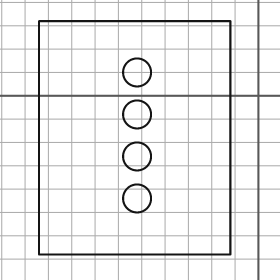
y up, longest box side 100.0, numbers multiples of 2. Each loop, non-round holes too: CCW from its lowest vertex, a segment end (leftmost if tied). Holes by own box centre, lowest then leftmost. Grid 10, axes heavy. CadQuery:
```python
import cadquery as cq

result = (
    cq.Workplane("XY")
    .moveTo(-94.0, -68.0)
    .lineTo(-12.0, -68.0)
    .lineTo(-12.0, 32.0)
    .lineTo(-94.0, 32.0)
    .close()
    .moveTo(-52.0, -44.0)
    .circle(6.0)
    .moveTo(-52.0, -26.0)
    .circle(6.0)
    .moveTo(-52.0, -8.0)
    .circle(6.0)
    .moveTo(-52.0, 10.0)
    .circle(6.0)
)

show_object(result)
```